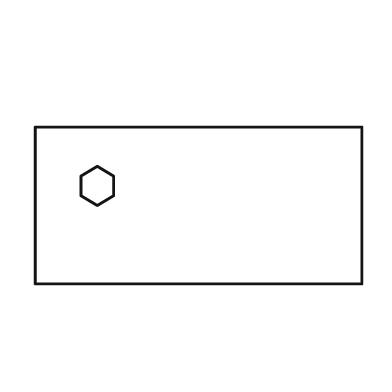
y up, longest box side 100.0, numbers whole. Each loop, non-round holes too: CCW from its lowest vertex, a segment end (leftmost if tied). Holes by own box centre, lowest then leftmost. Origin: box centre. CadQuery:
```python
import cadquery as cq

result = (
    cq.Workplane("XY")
    .moveTo(-50.0, -24.0)
    .lineTo(50.0, -24.0)
    .lineTo(50.0, 24.0)
    .lineTo(-50.0, 24.0)
    .close()
    .moveTo(-31.0, 0.0)
    .lineTo(-26.0, 3.0)
    .lineTo(-26.0, 9.0)
    .lineTo(-31.0, 12.0)
    .lineTo(-36.0, 9.0)
    .lineTo(-36.0, 3.0)
    .close()
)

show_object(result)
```